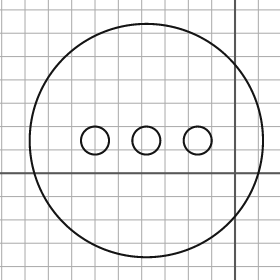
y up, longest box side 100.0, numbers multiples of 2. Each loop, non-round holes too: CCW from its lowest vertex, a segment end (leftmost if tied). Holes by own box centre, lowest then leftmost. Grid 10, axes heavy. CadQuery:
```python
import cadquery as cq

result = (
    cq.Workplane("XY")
    .moveTo(-38.0, 14.0)
    .circle(50.0)
    .moveTo(-60.0, 14.0)
    .circle(6.0)
    .moveTo(-38.0, 14.0)
    .circle(6.0)
    .moveTo(-16.0, 14.0)
    .circle(6.0)
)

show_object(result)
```